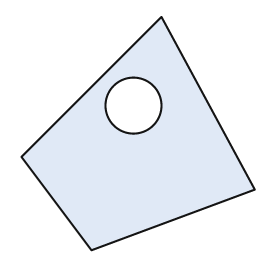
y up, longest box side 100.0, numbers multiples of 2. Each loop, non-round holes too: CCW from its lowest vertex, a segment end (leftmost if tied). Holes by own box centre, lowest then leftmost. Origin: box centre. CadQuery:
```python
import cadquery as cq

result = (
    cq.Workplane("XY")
    .moveTo(-20.0, -50.0)
    .lineTo(50.0, -24.0)
    .lineTo(10.0, 50.0)
    .lineTo(-50.0, -10.0)
    .close()
    .moveTo(-2.0, 12.0)
    .circle(12.0)
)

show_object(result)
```